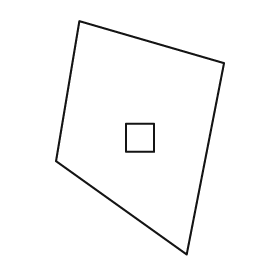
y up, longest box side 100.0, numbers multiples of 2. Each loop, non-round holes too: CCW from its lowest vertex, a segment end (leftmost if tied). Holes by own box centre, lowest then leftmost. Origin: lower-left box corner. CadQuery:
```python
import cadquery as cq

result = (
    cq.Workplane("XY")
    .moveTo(56.0, 0.0)
    .lineTo(72.0, 82.0)
    .lineTo(10.0, 100.0)
    .lineTo(0.0, 40.0)
    .close()
    .moveTo(30.0, 44.0)
    .lineTo(42.0, 44.0)
    .lineTo(42.0, 56.0)
    .lineTo(30.0, 56.0)
    .close()
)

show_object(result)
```